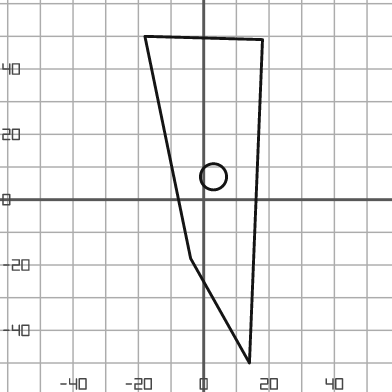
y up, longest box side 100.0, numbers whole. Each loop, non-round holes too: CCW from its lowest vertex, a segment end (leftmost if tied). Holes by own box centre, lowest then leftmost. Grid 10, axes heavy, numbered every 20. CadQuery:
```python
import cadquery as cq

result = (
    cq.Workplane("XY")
    .moveTo(14.0, -50.0)
    .lineTo(18.0, 49.0)
    .lineTo(-18.0, 50.0)
    .lineTo(-4.0, -18.0)
    .close()
    .moveTo(3.0, 7.0)
    .circle(4.0)
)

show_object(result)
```